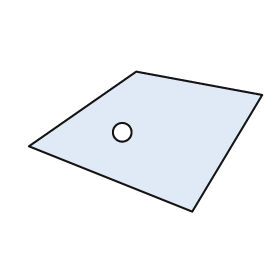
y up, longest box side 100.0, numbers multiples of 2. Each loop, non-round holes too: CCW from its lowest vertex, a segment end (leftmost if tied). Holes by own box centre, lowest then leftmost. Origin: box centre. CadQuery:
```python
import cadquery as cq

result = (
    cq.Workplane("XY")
    .moveTo(20.0, -30.0)
    .lineTo(50.0, 20.0)
    .lineTo(-4.0, 30.0)
    .lineTo(-50.0, -2.0)
    .close()
    .moveTo(-10.0, 4.0)
    .circle(4.0)
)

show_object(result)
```